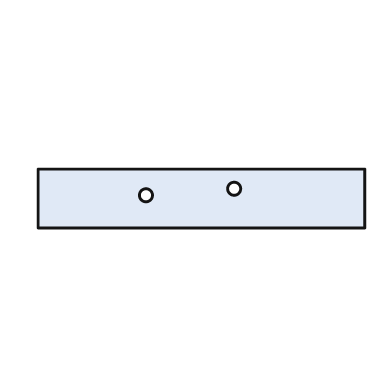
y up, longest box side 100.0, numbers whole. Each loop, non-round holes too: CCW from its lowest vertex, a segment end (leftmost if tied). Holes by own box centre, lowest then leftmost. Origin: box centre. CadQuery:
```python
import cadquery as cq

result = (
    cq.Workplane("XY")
    .moveTo(-50.0, -9.0)
    .lineTo(50.0, -9.0)
    .lineTo(50.0, 9.0)
    .lineTo(-50.0, 9.0)
    .close()
    .moveTo(-17.0, 1.0)
    .circle(2.0)
    .moveTo(10.0, 3.0)
    .circle(2.0)
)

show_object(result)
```